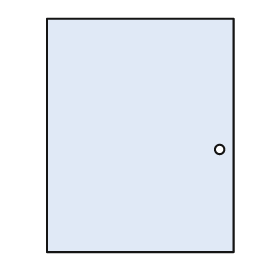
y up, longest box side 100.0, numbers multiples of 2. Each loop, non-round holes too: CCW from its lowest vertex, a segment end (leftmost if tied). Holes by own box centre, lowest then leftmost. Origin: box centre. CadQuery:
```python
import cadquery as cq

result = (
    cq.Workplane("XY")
    .moveTo(-40.0, -50.0)
    .lineTo(40.0, -50.0)
    .lineTo(40.0, 50.0)
    .lineTo(-40.0, 50.0)
    .close()
    .moveTo(34.0, -6.0)
    .circle(2.0)
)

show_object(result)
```